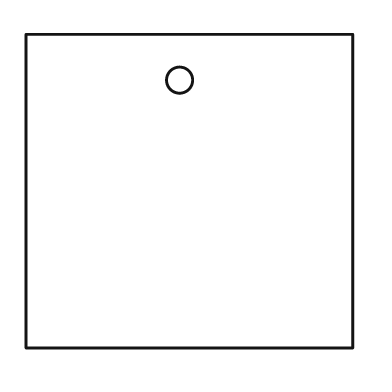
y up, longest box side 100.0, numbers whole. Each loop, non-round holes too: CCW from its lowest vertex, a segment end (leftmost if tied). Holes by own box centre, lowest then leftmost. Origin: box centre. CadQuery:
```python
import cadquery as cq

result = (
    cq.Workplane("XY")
    .moveTo(-50.0, -48.0)
    .lineTo(50.0, -48.0)
    .lineTo(50.0, 48.0)
    .lineTo(-50.0, 48.0)
    .close()
    .moveTo(-3.0, 34.0)
    .circle(4.0)
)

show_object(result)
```